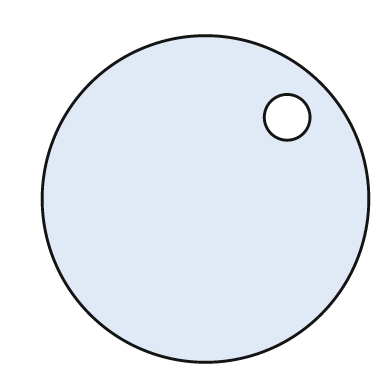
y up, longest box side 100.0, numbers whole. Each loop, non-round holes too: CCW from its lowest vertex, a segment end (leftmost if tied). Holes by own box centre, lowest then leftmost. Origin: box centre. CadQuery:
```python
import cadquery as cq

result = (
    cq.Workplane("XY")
    .moveTo(0.0, 0.0)
    .circle(50.0)
    .moveTo(25.0, 25.0)
    .circle(7.0)
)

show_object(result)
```